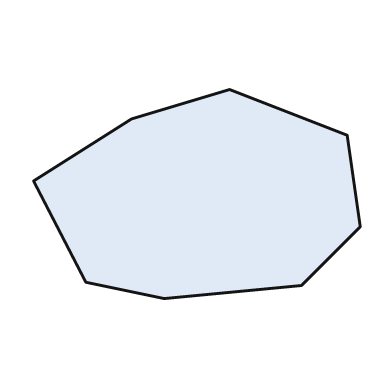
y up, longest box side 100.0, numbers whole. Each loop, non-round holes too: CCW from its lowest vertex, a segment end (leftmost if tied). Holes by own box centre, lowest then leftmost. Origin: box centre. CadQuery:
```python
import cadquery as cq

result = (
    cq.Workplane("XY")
    .moveTo(-10.0, -32.0)
    .lineTo(32.0, -28.0)
    .lineTo(50.0, -10.0)
    .lineTo(46.0, 18.0)
    .lineTo(10.0, 32.0)
    .lineTo(-20.0, 23.0)
    .lineTo(-50.0, 4.0)
    .lineTo(-34.0, -27.0)
    .close()
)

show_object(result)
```